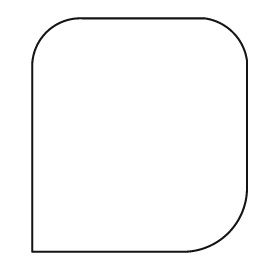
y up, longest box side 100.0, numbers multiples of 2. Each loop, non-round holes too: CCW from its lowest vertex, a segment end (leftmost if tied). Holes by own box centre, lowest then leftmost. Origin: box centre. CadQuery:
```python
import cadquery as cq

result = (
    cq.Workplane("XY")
    .moveTo(-46.0, -50.0)
    .lineTo(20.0, -50.0)
    .threePointArc((38.0, -42.0), (46.0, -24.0))
    .lineTo(46.0, 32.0)
    .threePointArc((40.0, 44.0), (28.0, 50.0))
    .lineTo(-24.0, 50.0)
    .threePointArc((-40.0, 44.0), (-46.0, 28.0))
    .close()
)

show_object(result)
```